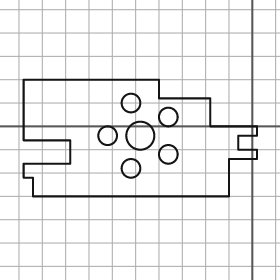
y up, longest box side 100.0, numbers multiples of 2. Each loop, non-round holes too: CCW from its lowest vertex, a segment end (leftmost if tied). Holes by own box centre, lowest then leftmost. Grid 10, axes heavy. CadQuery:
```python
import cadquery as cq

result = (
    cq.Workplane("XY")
    .moveTo(-94.0, -30.0)
    .lineTo(-10.0, -30.0)
    .lineTo(-10.0, -14.0)
    .lineTo(2.0, -14.0)
    .lineTo(2.0, -10.0)
    .lineTo(-6.0, -10.0)
    .lineTo(-6.0, -4.0)
    .lineTo(2.0, -4.0)
    .lineTo(2.0, 0.0)
    .lineTo(-18.0, 0.0)
    .lineTo(-18.0, 12.0)
    .lineTo(-40.0, 12.0)
    .lineTo(-40.0, 20.0)
    .lineTo(-98.0, 20.0)
    .lineTo(-98.0, -6.0)
    .lineTo(-78.0, -6.0)
    .lineTo(-78.0, -16.0)
    .lineTo(-98.0, -16.0)
    .lineTo(-98.0, -22.0)
    .lineTo(-94.0, -22.0)
    .close()
    .moveTo(-52.0, -18.0)
    .circle(4.0)
    .moveTo(-36.0, -12.0)
    .circle(4.0)
    .moveTo(-62.0, -4.0)
    .circle(4.0)
    .moveTo(-48.0, -4.0)
    .circle(6.0)
    .moveTo(-36.0, 4.0)
    .circle(4.0)
    .moveTo(-52.0, 10.0)
    .circle(4.0)
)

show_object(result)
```